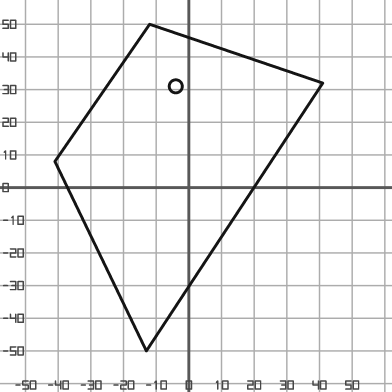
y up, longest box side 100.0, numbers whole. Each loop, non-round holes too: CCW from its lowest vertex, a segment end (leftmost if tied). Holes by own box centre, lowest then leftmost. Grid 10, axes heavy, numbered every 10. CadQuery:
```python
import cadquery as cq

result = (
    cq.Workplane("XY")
    .moveTo(-13.0, -50.0)
    .lineTo(41.0, 32.0)
    .lineTo(-12.0, 50.0)
    .lineTo(-41.0, 8.0)
    .close()
    .moveTo(-4.0, 31.0)
    .circle(2.0)
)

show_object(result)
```